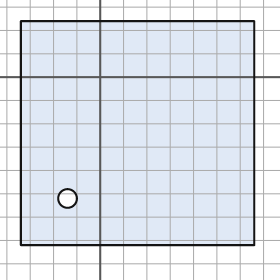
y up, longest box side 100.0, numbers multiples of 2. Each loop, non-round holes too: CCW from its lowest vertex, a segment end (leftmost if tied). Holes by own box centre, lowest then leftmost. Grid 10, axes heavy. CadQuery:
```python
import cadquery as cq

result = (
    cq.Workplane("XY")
    .moveTo(-34.0, -72.0)
    .lineTo(66.0, -72.0)
    .lineTo(66.0, 24.0)
    .lineTo(-34.0, 24.0)
    .close()
    .moveTo(-14.0, -52.0)
    .circle(4.0)
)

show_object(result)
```